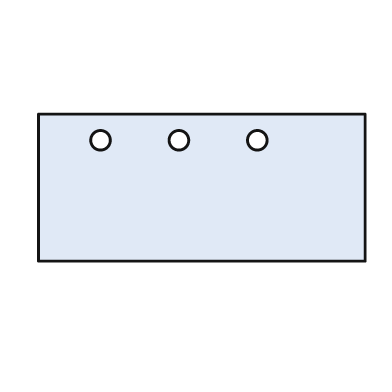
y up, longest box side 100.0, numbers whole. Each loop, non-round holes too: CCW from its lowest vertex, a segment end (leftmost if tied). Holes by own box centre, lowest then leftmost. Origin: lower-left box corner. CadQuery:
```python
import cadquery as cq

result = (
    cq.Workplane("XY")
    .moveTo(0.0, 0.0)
    .lineTo(100.0, 0.0)
    .lineTo(100.0, 45.0)
    .lineTo(0.0, 45.0)
    .close()
    .moveTo(19.0, 37.0)
    .circle(3.0)
    .moveTo(43.0, 37.0)
    .circle(3.0)
    .moveTo(67.0, 37.0)
    .circle(3.0)
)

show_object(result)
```